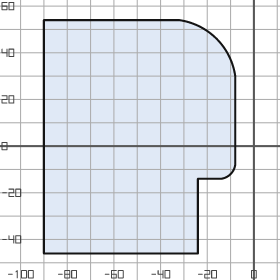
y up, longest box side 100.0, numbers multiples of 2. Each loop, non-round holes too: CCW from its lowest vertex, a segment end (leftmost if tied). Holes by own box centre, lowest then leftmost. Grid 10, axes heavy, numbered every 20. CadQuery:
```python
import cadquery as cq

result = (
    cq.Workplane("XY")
    .moveTo(-90.0, -46.0)
    .lineTo(-24.0, -46.0)
    .lineTo(-24.0, -14.0)
    .lineTo(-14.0, -14.0)
    .threePointArc((-10.0, -12.0), (-8.0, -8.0))
    .lineTo(-8.0, 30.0)
    .threePointArc((-16.0, 46.0), (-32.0, 54.0))
    .lineTo(-90.0, 54.0)
    .close()
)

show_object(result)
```